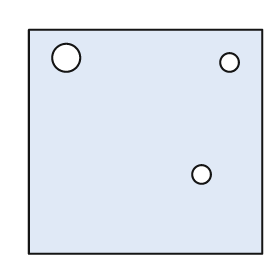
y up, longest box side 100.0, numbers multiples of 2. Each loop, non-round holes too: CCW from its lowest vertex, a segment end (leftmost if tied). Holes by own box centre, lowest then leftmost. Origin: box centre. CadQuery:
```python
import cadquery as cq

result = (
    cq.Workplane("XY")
    .moveTo(-50.0, -48.0)
    .lineTo(50.0, -48.0)
    .lineTo(50.0, 48.0)
    .lineTo(-50.0, 48.0)
    .close()
    .moveTo(24.0, -14.0)
    .circle(4.0)
    .moveTo(36.0, 34.0)
    .circle(4.0)
    .moveTo(-34.0, 36.0)
    .circle(6.0)
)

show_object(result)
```